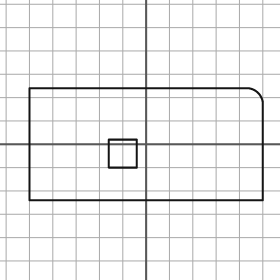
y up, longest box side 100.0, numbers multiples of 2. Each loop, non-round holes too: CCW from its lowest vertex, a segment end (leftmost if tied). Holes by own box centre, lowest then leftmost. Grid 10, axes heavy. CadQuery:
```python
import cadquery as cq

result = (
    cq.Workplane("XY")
    .moveTo(-50.0, -24.0)
    .lineTo(50.0, -24.0)
    .lineTo(50.0, 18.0)
    .threePointArc((48.0, 22.0), (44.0, 24.0))
    .lineTo(-50.0, 24.0)
    .close()
    .moveTo(-16.0, -10.0)
    .lineTo(-4.0, -10.0)
    .lineTo(-4.0, 2.0)
    .lineTo(-16.0, 2.0)
    .close()
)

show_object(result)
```